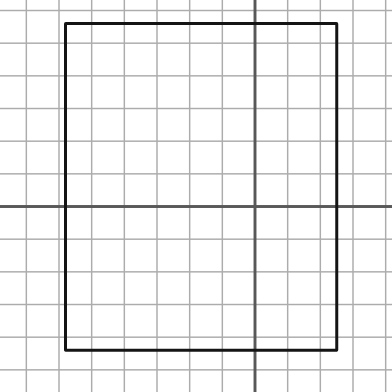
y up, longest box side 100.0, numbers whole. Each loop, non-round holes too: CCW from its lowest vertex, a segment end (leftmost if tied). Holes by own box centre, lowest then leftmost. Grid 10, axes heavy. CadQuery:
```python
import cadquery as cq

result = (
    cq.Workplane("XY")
    .moveTo(-58.0, -44.0)
    .lineTo(25.0, -44.0)
    .lineTo(25.0, 56.0)
    .lineTo(-58.0, 56.0)
    .close()
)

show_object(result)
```